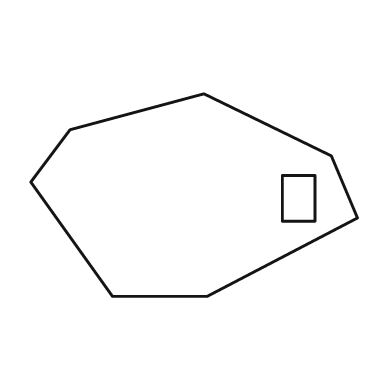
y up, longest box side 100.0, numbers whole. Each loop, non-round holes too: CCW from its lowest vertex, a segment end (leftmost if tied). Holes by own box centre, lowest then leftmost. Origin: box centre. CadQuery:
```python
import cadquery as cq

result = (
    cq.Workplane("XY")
    .moveTo(-25.0, -31.0)
    .lineTo(4.0, -31.0)
    .lineTo(50.0, -7.0)
    .lineTo(42.0, 12.0)
    .lineTo(3.0, 31.0)
    .lineTo(-38.0, 20.0)
    .lineTo(-50.0, 4.0)
    .close()
    .moveTo(27.0, -8.0)
    .lineTo(37.0, -8.0)
    .lineTo(37.0, 6.0)
    .lineTo(27.0, 6.0)
    .close()
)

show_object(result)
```